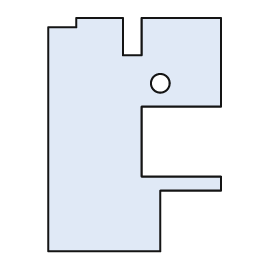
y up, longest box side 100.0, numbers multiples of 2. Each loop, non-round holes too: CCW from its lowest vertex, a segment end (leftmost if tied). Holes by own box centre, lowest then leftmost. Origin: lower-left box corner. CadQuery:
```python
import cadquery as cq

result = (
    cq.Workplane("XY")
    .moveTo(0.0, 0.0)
    .lineTo(48.0, 0.0)
    .lineTo(48.0, 26.0)
    .lineTo(74.0, 26.0)
    .lineTo(74.0, 32.0)
    .lineTo(40.0, 32.0)
    .lineTo(40.0, 62.0)
    .lineTo(74.0, 62.0)
    .lineTo(74.0, 100.0)
    .lineTo(40.0, 100.0)
    .lineTo(40.0, 84.0)
    .lineTo(32.0, 84.0)
    .lineTo(32.0, 100.0)
    .lineTo(12.0, 100.0)
    .lineTo(12.0, 96.0)
    .lineTo(0.0, 96.0)
    .close()
    .moveTo(48.0, 72.0)
    .circle(4.0)
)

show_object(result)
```